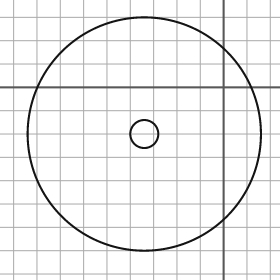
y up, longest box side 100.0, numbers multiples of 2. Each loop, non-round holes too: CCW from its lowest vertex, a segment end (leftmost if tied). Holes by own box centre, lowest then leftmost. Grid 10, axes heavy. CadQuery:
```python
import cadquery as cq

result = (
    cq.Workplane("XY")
    .moveTo(-34.0, -20.0)
    .circle(50.0)
    .moveTo(-34.0, -20.0)
    .circle(6.0)
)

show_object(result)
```